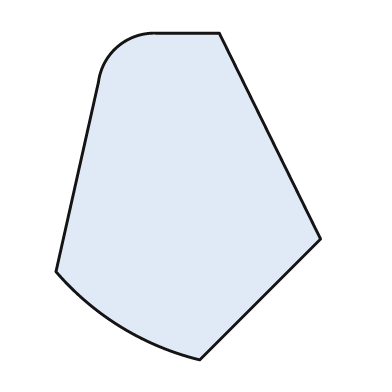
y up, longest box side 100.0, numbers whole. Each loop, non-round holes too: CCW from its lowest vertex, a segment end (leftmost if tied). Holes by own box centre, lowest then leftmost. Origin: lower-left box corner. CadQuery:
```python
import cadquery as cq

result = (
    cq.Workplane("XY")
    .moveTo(44.0, 0.0)
    .lineTo(81.0, 37.0)
    .lineTo(50.0, 100.0)
    .lineTo(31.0, 100.0)
    .threePointArc((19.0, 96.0), (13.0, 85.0))
    .lineTo(0.0, 27.0)
    .threePointArc((20.0, 10.0), (44.0, 0.0))
    .close()
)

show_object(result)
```